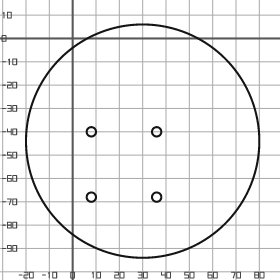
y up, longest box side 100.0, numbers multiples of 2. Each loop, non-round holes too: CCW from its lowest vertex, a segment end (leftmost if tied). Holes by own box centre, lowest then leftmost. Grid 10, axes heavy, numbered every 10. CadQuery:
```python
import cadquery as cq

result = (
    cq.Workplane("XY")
    .moveTo(30.0, -44.0)
    .circle(50.0)
    .moveTo(8.0, -68.0)
    .circle(2.0)
    .moveTo(36.0, -68.0)
    .circle(2.0)
    .moveTo(8.0, -40.0)
    .circle(2.0)
    .moveTo(36.0, -40.0)
    .circle(2.0)
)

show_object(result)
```